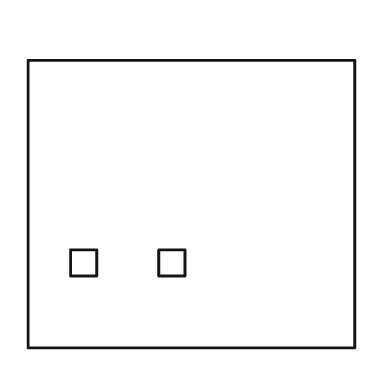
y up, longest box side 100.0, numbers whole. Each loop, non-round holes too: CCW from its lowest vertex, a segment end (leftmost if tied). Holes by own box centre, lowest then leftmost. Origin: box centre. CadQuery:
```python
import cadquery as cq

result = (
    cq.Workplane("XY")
    .moveTo(-50.0, -44.0)
    .lineTo(50.0, -44.0)
    .lineTo(50.0, 44.0)
    .lineTo(-50.0, 44.0)
    .close()
    .moveTo(-37.0, -22.0)
    .lineTo(-29.0, -22.0)
    .lineTo(-29.0, -14.0)
    .lineTo(-37.0, -14.0)
    .close()
    .moveTo(-10.0, -22.0)
    .lineTo(-2.0, -22.0)
    .lineTo(-2.0, -14.0)
    .lineTo(-10.0, -14.0)
    .close()
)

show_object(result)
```